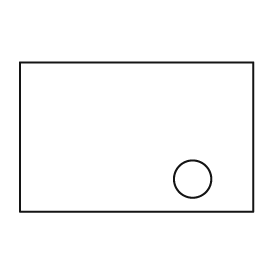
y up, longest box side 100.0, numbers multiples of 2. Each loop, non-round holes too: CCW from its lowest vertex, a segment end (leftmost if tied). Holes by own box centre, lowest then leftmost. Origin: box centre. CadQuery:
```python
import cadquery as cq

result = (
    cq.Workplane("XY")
    .moveTo(-50.0, -32.0)
    .lineTo(50.0, -32.0)
    .lineTo(50.0, 32.0)
    .lineTo(-50.0, 32.0)
    .close()
    .moveTo(24.0, -18.0)
    .circle(8.0)
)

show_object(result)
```